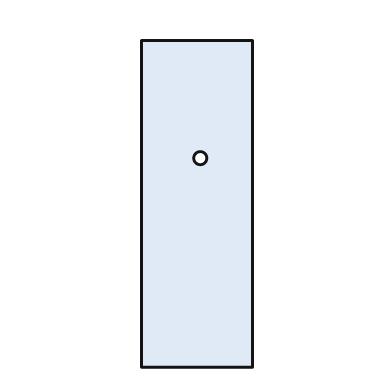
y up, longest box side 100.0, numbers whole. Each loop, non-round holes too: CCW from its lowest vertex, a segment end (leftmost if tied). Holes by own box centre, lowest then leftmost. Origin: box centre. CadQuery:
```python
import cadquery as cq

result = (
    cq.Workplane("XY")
    .moveTo(-17.0, -50.0)
    .lineTo(17.0, -50.0)
    .lineTo(17.0, 50.0)
    .lineTo(-17.0, 50.0)
    .close()
    .moveTo(1.0, 14.0)
    .circle(2.0)
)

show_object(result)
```